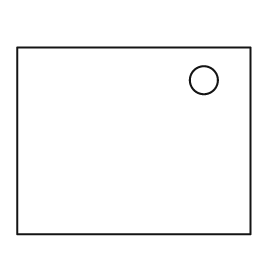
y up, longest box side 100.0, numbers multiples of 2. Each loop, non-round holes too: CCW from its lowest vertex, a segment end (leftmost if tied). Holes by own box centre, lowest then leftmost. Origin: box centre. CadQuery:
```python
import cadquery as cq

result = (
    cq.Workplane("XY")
    .moveTo(-50.0, -40.0)
    .lineTo(50.0, -40.0)
    .lineTo(50.0, 40.0)
    .lineTo(-50.0, 40.0)
    .close()
    .moveTo(30.0, 26.0)
    .circle(6.0)
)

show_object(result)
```